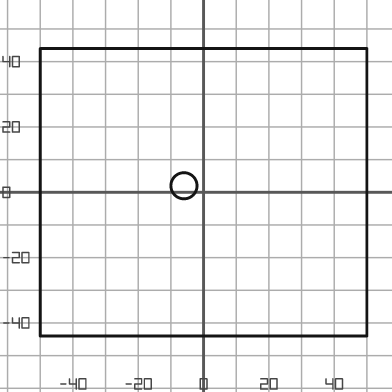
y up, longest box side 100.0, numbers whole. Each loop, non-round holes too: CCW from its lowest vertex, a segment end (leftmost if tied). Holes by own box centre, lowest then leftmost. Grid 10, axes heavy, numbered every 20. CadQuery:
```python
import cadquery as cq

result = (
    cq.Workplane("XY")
    .moveTo(-50.0, -44.0)
    .lineTo(50.0, -44.0)
    .lineTo(50.0, 44.0)
    .lineTo(-50.0, 44.0)
    .close()
    .moveTo(-6.0, 2.0)
    .circle(4.0)
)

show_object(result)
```